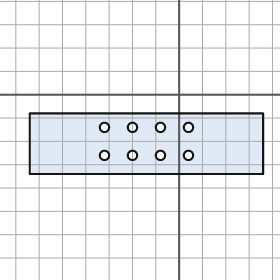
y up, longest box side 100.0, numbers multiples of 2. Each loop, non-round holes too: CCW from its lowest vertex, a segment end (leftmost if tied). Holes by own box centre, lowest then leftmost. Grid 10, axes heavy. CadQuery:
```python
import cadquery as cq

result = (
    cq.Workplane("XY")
    .moveTo(-64.0, -34.0)
    .lineTo(36.0, -34.0)
    .lineTo(36.0, -8.0)
    .lineTo(-64.0, -8.0)
    .close()
    .moveTo(-32.0, -26.0)
    .circle(2.0)
    .moveTo(-20.0, -26.0)
    .circle(2.0)
    .moveTo(-8.0, -26.0)
    .circle(2.0)
    .moveTo(4.0, -26.0)
    .circle(2.0)
    .moveTo(-32.0, -14.0)
    .circle(2.0)
    .moveTo(-20.0, -14.0)
    .circle(2.0)
    .moveTo(-8.0, -14.0)
    .circle(2.0)
    .moveTo(4.0, -14.0)
    .circle(2.0)
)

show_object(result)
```